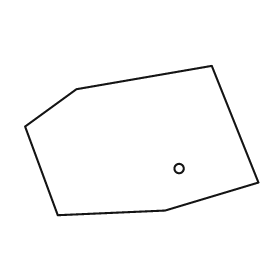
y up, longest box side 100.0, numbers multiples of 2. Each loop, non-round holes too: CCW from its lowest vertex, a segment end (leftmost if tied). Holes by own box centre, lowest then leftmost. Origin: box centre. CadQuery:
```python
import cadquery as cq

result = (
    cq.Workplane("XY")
    .moveTo(-36.0, -32.0)
    .lineTo(10.0, -30.0)
    .lineTo(50.0, -18.0)
    .lineTo(30.0, 32.0)
    .lineTo(-28.0, 22.0)
    .lineTo(-50.0, 6.0)
    .close()
    .moveTo(16.0, -12.0)
    .circle(2.0)
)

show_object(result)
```